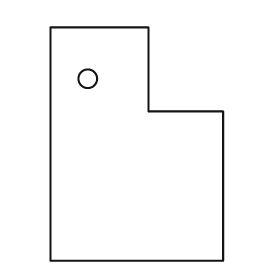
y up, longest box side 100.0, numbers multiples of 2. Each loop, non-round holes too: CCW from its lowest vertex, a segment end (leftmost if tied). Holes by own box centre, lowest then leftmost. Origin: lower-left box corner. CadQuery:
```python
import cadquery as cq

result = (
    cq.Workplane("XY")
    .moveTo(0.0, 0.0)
    .lineTo(74.0, 0.0)
    .lineTo(74.0, 64.0)
    .lineTo(42.0, 64.0)
    .lineTo(42.0, 100.0)
    .lineTo(0.0, 100.0)
    .close()
    .moveTo(16.0, 78.0)
    .circle(4.0)
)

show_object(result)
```